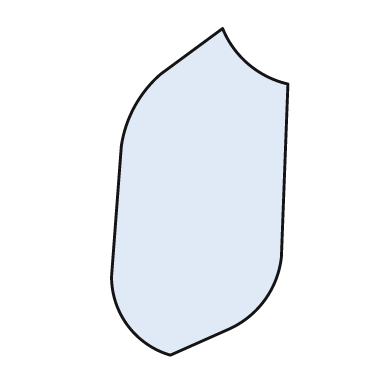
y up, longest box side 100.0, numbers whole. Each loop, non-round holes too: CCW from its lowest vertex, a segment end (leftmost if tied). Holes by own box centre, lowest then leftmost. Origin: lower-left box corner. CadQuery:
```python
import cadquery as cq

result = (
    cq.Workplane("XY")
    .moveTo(18.0, 0.0)
    .lineTo(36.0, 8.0)
    .threePointArc((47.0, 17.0), (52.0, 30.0))
    .lineTo(54.0, 83.0)
    .threePointArc((42.0, 89.0), (34.0, 100.0))
    .lineTo(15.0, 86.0)
    .threePointArc((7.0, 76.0), (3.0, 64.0))
    .lineTo(0.0, 24.0)
    .threePointArc((5.0, 9.0), (18.0, 0.0))
    .close()
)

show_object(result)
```